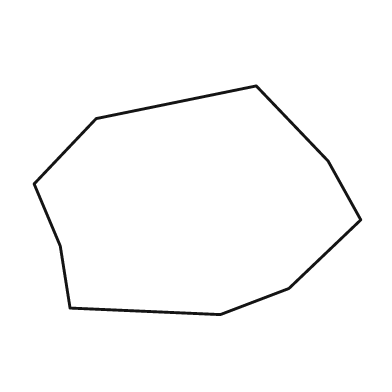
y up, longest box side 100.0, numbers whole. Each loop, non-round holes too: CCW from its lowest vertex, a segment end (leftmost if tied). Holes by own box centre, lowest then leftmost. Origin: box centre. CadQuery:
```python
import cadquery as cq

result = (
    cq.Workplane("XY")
    .moveTo(7.0, -35.0)
    .lineTo(28.0, -27.0)
    .lineTo(50.0, -6.0)
    .lineTo(40.0, 12.0)
    .lineTo(18.0, 35.0)
    .lineTo(-31.0, 25.0)
    .lineTo(-50.0, 5.0)
    .lineTo(-42.0, -14.0)
    .lineTo(-39.0, -33.0)
    .close()
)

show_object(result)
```